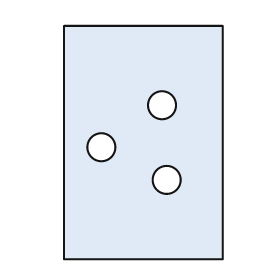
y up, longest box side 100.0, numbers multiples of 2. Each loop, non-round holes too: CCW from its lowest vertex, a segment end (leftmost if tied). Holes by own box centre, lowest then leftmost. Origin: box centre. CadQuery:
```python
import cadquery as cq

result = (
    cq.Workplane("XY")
    .moveTo(-34.0, -50.0)
    .lineTo(34.0, -50.0)
    .lineTo(34.0, 50.0)
    .lineTo(-34.0, 50.0)
    .close()
    .moveTo(10.0, -16.0)
    .circle(6.0)
    .moveTo(-18.0, -2.0)
    .circle(6.0)
    .moveTo(8.0, 16.0)
    .circle(6.0)
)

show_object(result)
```